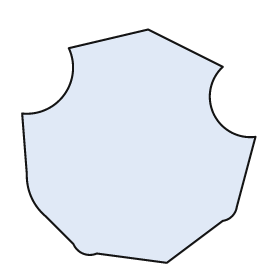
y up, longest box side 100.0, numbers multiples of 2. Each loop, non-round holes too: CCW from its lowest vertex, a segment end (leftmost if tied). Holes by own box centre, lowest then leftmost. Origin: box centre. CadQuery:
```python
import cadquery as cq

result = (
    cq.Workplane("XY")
    .moveTo(12.0, -50.0)
    .lineTo(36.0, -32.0)
    .threePointArc((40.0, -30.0), (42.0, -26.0))
    .lineTo(50.0, 4.0)
    .threePointArc((32.0, 14.0), (36.0, 34.0))
    .lineTo(4.0, 50.0)
    .lineTo(-30.0, 42.0)
    .threePointArc((-32.0, 22.0), (-50.0, 14.0))
    .lineTo(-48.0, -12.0)
    .threePointArc((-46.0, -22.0), (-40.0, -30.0))
    .lineTo(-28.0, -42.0)
    .threePointArc((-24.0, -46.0), (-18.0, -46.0))
    .close()
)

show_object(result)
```